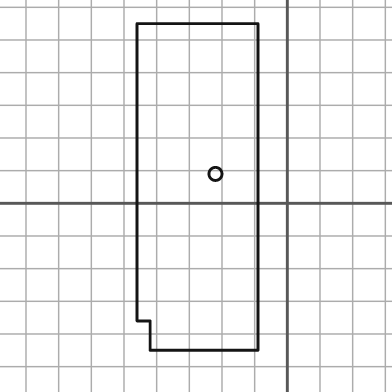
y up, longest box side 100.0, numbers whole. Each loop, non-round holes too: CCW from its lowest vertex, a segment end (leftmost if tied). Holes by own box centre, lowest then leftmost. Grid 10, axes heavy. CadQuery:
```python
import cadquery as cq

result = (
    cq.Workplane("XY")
    .moveTo(-42.0, -45.0)
    .lineTo(-9.0, -45.0)
    .lineTo(-9.0, 55.0)
    .lineTo(-46.0, 55.0)
    .lineTo(-46.0, -36.0)
    .lineTo(-42.0, -36.0)
    .close()
    .moveTo(-22.0, 9.0)
    .circle(2.0)
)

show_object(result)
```